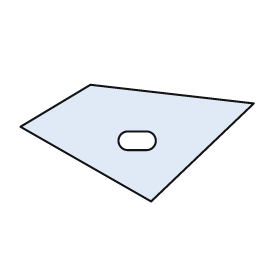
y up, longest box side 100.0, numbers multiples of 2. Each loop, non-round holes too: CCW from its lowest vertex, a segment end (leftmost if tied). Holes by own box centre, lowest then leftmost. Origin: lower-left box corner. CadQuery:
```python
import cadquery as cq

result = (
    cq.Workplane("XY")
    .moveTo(56.0, 0.0)
    .lineTo(100.0, 42.0)
    .lineTo(30.0, 50.0)
    .lineTo(0.0, 32.0)
    .close()
    .moveTo(46.0, 22.0)
    .lineTo(54.0, 22.0)
    .threePointArc((58.0, 26.0), (54.0, 30.0))
    .lineTo(46.0, 30.0)
    .threePointArc((42.0, 26.0), (46.0, 22.0))
    .close()
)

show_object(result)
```